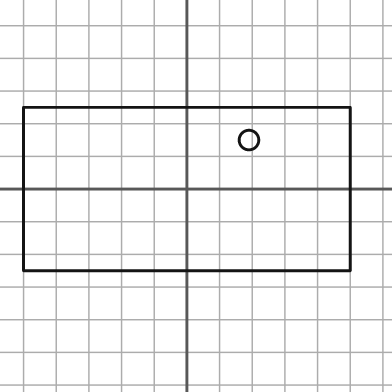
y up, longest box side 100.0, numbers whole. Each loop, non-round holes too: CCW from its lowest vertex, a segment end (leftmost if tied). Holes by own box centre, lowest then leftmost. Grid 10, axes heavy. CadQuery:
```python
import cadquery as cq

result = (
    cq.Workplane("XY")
    .moveTo(-50.0, -25.0)
    .lineTo(50.0, -25.0)
    .lineTo(50.0, 25.0)
    .lineTo(-50.0, 25.0)
    .close()
    .moveTo(19.0, 15.0)
    .circle(3.0)
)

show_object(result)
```